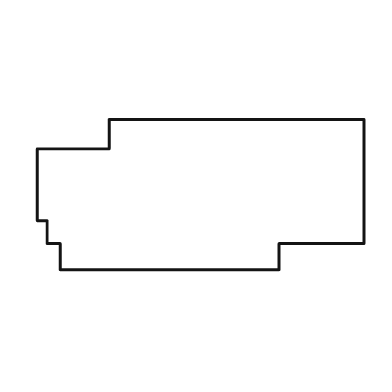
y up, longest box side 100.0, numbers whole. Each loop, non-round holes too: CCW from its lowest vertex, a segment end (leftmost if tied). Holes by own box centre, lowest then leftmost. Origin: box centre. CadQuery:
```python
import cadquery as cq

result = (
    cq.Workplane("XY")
    .moveTo(-43.0, -23.0)
    .lineTo(24.0, -23.0)
    .lineTo(24.0, -15.0)
    .lineTo(50.0, -15.0)
    .lineTo(50.0, 23.0)
    .lineTo(-28.0, 23.0)
    .lineTo(-28.0, 14.0)
    .lineTo(-50.0, 14.0)
    .lineTo(-50.0, -8.0)
    .lineTo(-47.0, -8.0)
    .lineTo(-47.0, -15.0)
    .lineTo(-43.0, -15.0)
    .close()
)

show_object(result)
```